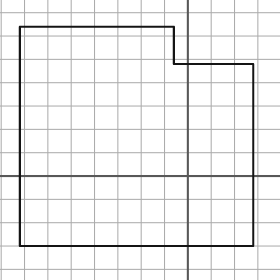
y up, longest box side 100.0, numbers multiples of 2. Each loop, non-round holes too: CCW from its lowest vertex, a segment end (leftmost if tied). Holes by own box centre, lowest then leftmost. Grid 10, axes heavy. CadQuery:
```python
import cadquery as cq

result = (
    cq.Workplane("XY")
    .moveTo(-72.0, -30.0)
    .lineTo(28.0, -30.0)
    .lineTo(28.0, 48.0)
    .lineTo(-6.0, 48.0)
    .lineTo(-6.0, 64.0)
    .lineTo(-72.0, 64.0)
    .close()
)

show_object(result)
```